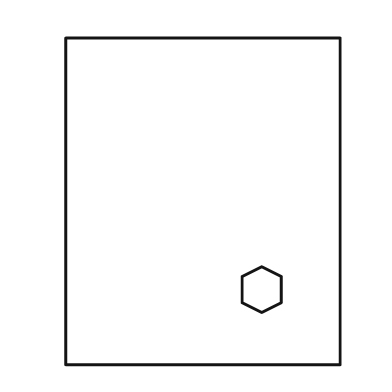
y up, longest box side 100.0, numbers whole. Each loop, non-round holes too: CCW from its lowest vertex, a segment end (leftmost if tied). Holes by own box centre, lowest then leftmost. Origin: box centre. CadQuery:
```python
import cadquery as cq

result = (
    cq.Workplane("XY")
    .moveTo(-42.0, -50.0)
    .lineTo(42.0, -50.0)
    .lineTo(42.0, 50.0)
    .lineTo(-42.0, 50.0)
    .close()
    .moveTo(18.0, -34.0)
    .lineTo(24.0, -31.0)
    .lineTo(24.0, -23.0)
    .lineTo(18.0, -20.0)
    .lineTo(12.0, -23.0)
    .lineTo(12.0, -31.0)
    .close()
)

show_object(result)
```